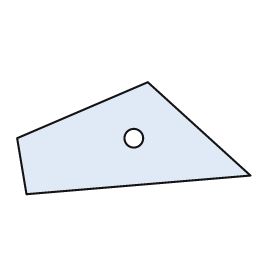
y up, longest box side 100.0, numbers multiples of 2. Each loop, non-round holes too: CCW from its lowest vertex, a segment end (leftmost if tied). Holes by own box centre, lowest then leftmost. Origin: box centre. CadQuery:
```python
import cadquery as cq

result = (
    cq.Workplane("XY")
    .moveTo(-46.0, -24.0)
    .lineTo(50.0, -16.0)
    .lineTo(6.0, 24.0)
    .lineTo(-50.0, 0.0)
    .close()
    .moveTo(0.0, 0.0)
    .circle(4.0)
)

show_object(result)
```